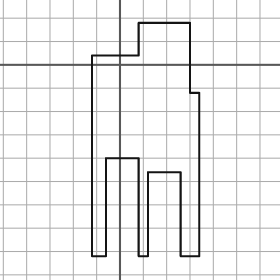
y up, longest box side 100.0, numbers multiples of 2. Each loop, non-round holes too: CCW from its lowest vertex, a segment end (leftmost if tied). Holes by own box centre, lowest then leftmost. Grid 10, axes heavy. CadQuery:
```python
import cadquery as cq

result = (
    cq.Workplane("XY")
    .moveTo(-12.0, -82.0)
    .lineTo(-6.0, -82.0)
    .lineTo(-6.0, -40.0)
    .lineTo(8.0, -40.0)
    .lineTo(8.0, -82.0)
    .lineTo(12.0, -82.0)
    .lineTo(12.0, -46.0)
    .lineTo(26.0, -46.0)
    .lineTo(26.0, -82.0)
    .lineTo(34.0, -82.0)
    .lineTo(34.0, -12.0)
    .lineTo(30.0, -12.0)
    .lineTo(30.0, 18.0)
    .lineTo(8.0, 18.0)
    .lineTo(8.0, 4.0)
    .lineTo(-12.0, 4.0)
    .close()
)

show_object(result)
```